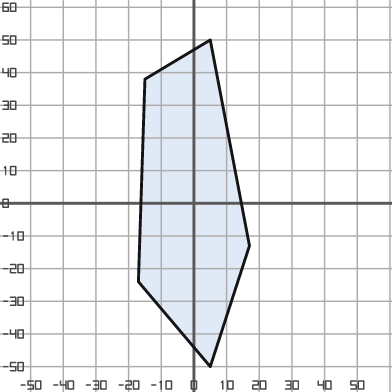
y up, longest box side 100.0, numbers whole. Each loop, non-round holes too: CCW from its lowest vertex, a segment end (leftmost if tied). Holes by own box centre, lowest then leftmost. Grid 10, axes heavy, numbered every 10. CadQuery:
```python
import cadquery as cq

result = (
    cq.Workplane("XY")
    .moveTo(5.0, -50.0)
    .lineTo(17.0, -13.0)
    .lineTo(5.0, 50.0)
    .lineTo(-15.0, 38.0)
    .lineTo(-17.0, -24.0)
    .close()
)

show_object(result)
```